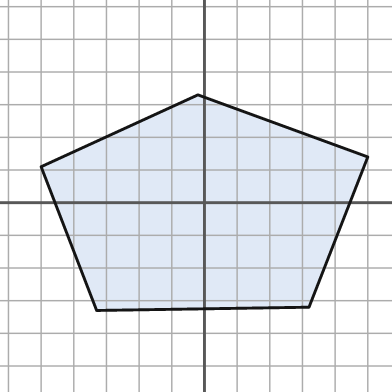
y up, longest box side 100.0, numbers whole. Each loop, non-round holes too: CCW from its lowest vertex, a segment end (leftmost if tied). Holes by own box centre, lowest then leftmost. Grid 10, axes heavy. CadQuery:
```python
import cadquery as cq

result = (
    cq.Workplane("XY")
    .moveTo(-33.0, -33.0)
    .lineTo(32.0, -32.0)
    .lineTo(50.0, 14.0)
    .lineTo(-2.0, 33.0)
    .lineTo(-50.0, 11.0)
    .close()
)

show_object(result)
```